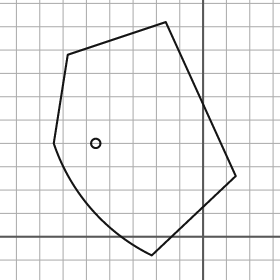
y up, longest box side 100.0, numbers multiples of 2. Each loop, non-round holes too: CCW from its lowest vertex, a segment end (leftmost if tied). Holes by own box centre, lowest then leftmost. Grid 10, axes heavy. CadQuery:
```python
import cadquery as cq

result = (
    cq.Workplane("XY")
    .moveTo(-22.0, -8.0)
    .lineTo(14.0, 26.0)
    .lineTo(-16.0, 92.0)
    .lineTo(-58.0, 78.0)
    .lineTo(-64.0, 40.0)
    .threePointArc((-48.0, 12.0), (-22.0, -8.0))
    .close()
    .moveTo(-46.0, 40.0)
    .circle(2.0)
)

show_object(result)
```